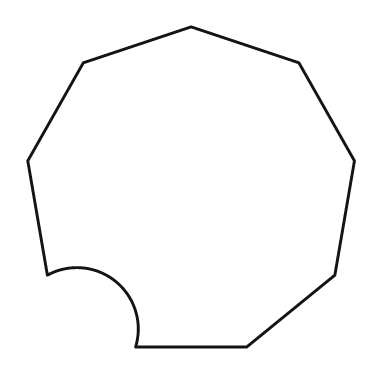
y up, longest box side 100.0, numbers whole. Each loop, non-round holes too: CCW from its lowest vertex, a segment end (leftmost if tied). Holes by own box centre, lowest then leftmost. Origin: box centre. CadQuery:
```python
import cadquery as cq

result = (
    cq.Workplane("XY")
    .moveTo(-17.0, -49.0)
    .lineTo(17.0, -49.0)
    .lineTo(44.0, -27.0)
    .lineTo(50.0, 8.0)
    .lineTo(33.0, 38.0)
    .lineTo(0.0, 49.0)
    .lineTo(-33.0, 38.0)
    .lineTo(-50.0, 8.0)
    .lineTo(-44.0, -27.0)
    .threePointArc((-23.0, -29.0), (-17.0, -49.0))
    .close()
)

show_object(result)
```